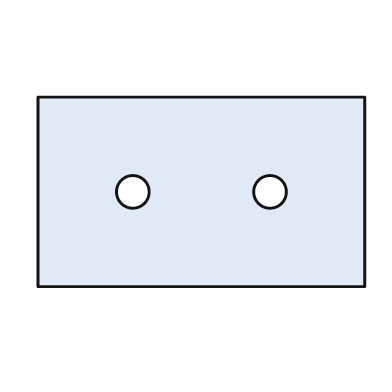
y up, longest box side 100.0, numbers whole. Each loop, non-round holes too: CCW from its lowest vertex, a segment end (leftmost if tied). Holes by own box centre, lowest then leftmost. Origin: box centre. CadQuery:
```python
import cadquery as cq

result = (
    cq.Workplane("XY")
    .moveTo(-50.0, -29.0)
    .lineTo(50.0, -29.0)
    .lineTo(50.0, 29.0)
    .lineTo(-50.0, 29.0)
    .close()
    .moveTo(-21.0, 0.0)
    .circle(5.0)
    .moveTo(21.0, 0.0)
    .circle(5.0)
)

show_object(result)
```